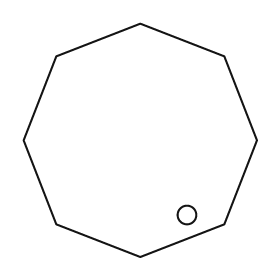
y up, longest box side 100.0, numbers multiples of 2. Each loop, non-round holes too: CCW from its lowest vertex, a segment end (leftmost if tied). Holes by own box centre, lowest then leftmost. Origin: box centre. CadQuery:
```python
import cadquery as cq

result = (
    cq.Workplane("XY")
    .moveTo(0.0, -50.0)
    .lineTo(36.0, -36.0)
    .lineTo(50.0, 0.0)
    .lineTo(36.0, 36.0)
    .lineTo(0.0, 50.0)
    .lineTo(-36.0, 36.0)
    .lineTo(-50.0, 0.0)
    .lineTo(-36.0, -36.0)
    .close()
    .moveTo(20.0, -32.0)
    .circle(4.0)
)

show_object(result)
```